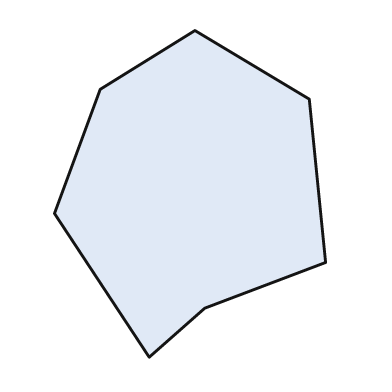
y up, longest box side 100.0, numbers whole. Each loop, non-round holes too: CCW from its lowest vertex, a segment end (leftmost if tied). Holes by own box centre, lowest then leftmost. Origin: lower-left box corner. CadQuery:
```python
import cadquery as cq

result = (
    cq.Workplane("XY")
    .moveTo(29.0, 0.0)
    .lineTo(46.0, 15.0)
    .lineTo(83.0, 29.0)
    .lineTo(78.0, 79.0)
    .lineTo(43.0, 100.0)
    .lineTo(14.0, 82.0)
    .lineTo(0.0, 44.0)
    .close()
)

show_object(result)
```